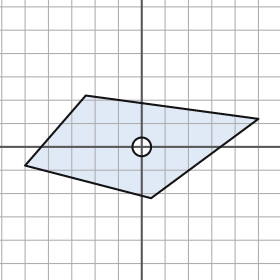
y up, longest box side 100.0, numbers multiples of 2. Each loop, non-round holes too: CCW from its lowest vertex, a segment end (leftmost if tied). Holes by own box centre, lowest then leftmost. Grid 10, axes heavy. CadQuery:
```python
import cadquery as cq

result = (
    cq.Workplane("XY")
    .moveTo(4.0, -22.0)
    .lineTo(50.0, 12.0)
    .lineTo(-24.0, 22.0)
    .lineTo(-50.0, -8.0)
    .close()
    .moveTo(0.0, 0.0)
    .circle(4.0)
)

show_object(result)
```